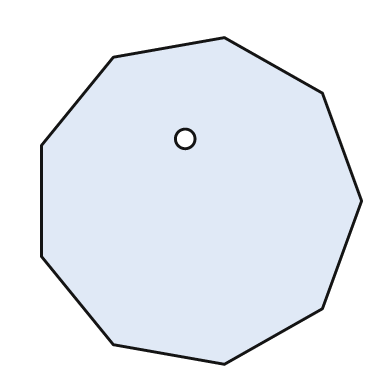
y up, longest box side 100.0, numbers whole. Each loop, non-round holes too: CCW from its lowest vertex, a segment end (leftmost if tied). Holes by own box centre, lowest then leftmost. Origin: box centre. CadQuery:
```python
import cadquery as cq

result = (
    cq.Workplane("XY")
    .moveTo(7.0, -50.0)
    .lineTo(37.0, -33.0)
    .lineTo(49.0, 0.0)
    .lineTo(37.0, 33.0)
    .lineTo(7.0, 50.0)
    .lineTo(-27.0, 44.0)
    .lineTo(-49.0, 17.0)
    .lineTo(-49.0, -17.0)
    .lineTo(-27.0, -44.0)
    .close()
    .moveTo(-5.0, 19.0)
    .circle(3.0)
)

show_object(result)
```